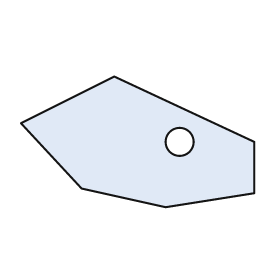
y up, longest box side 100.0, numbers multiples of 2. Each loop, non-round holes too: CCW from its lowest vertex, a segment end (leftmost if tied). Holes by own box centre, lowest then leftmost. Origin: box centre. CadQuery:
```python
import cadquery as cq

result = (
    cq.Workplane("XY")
    .moveTo(12.0, -28.0)
    .lineTo(50.0, -22.0)
    .lineTo(50.0, 0.0)
    .lineTo(-10.0, 28.0)
    .lineTo(-50.0, 8.0)
    .lineTo(-24.0, -20.0)
    .close()
    .moveTo(18.0, 0.0)
    .circle(6.0)
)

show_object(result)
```